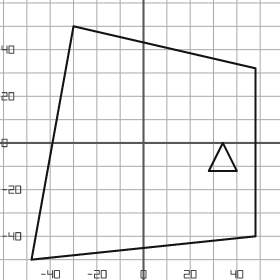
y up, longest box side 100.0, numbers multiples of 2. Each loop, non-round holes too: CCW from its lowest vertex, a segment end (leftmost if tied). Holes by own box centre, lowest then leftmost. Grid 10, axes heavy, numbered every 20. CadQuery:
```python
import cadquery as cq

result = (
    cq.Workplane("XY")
    .moveTo(-48.0, -50.0)
    .lineTo(48.0, -40.0)
    .lineTo(48.0, 32.0)
    .lineTo(-30.0, 50.0)
    .close()
    .moveTo(28.0, -12.0)
    .lineTo(40.0, -12.0)
    .lineTo(34.0, 0.0)
    .close()
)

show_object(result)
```